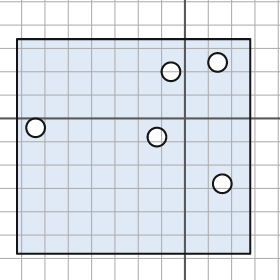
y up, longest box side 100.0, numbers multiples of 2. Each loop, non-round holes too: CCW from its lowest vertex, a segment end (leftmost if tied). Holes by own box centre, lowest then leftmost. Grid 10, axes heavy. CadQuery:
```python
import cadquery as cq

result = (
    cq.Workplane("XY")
    .moveTo(-72.0, -58.0)
    .lineTo(28.0, -58.0)
    .lineTo(28.0, 34.0)
    .lineTo(-72.0, 34.0)
    .close()
    .moveTo(16.0, -28.0)
    .circle(4.0)
    .moveTo(-12.0, -8.0)
    .circle(4.0)
    .moveTo(-64.0, -4.0)
    .circle(4.0)
    .moveTo(-6.0, 20.0)
    .circle(4.0)
    .moveTo(14.0, 24.0)
    .circle(4.0)
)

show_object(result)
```